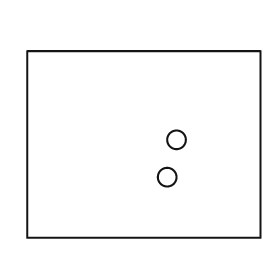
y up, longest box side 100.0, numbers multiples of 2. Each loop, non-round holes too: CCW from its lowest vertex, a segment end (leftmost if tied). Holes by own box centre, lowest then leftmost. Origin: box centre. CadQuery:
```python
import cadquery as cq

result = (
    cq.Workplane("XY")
    .moveTo(-50.0, -40.0)
    .lineTo(50.0, -40.0)
    .lineTo(50.0, 40.0)
    .lineTo(-50.0, 40.0)
    .close()
    .moveTo(10.0, -14.0)
    .circle(4.0)
    .moveTo(14.0, 2.0)
    .circle(4.0)
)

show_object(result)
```